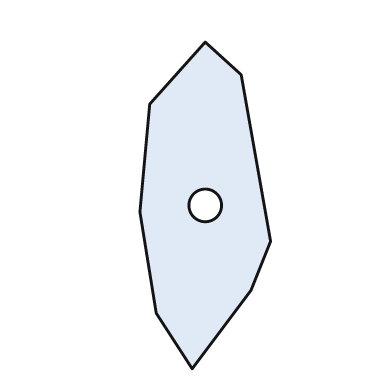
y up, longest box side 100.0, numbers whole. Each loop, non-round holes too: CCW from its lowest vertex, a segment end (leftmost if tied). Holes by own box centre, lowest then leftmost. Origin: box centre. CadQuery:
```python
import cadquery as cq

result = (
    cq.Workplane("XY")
    .moveTo(-4.0, -50.0)
    .lineTo(14.0, -26.0)
    .lineTo(20.0, -11.0)
    .lineTo(11.0, 40.0)
    .lineTo(0.0, 50.0)
    .lineTo(-17.0, 31.0)
    .lineTo(-20.0, -2.0)
    .lineTo(-15.0, -33.0)
    .close()
    .moveTo(0.0, 0.0)
    .circle(5.0)
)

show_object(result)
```